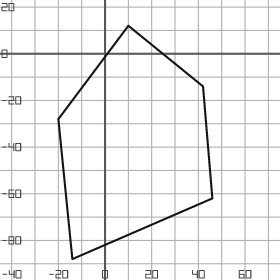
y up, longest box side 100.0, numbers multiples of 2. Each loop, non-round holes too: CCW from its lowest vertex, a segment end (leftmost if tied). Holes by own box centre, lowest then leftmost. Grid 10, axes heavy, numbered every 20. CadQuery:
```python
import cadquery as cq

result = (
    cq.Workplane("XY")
    .moveTo(-14.0, -88.0)
    .lineTo(46.0, -62.0)
    .lineTo(42.0, -14.0)
    .lineTo(10.0, 12.0)
    .lineTo(-20.0, -28.0)
    .close()
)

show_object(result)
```